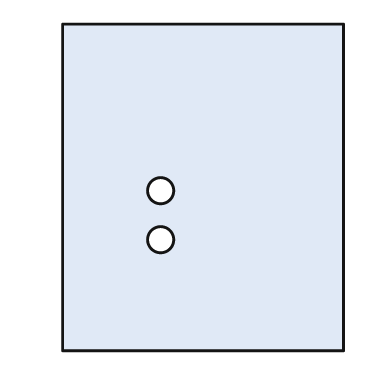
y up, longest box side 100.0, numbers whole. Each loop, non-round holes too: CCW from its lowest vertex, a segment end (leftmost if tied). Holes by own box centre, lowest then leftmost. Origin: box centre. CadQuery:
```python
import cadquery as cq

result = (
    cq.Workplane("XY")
    .moveTo(-43.0, -50.0)
    .lineTo(43.0, -50.0)
    .lineTo(43.0, 50.0)
    .lineTo(-43.0, 50.0)
    .close()
    .moveTo(-13.0, -16.0)
    .circle(4.0)
    .moveTo(-13.0, -1.0)
    .circle(4.0)
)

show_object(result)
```